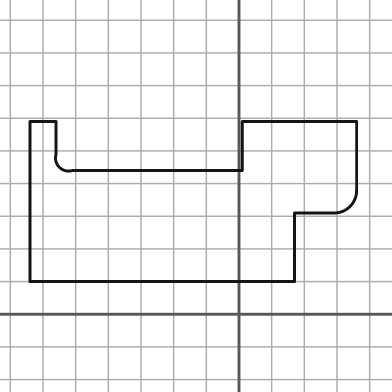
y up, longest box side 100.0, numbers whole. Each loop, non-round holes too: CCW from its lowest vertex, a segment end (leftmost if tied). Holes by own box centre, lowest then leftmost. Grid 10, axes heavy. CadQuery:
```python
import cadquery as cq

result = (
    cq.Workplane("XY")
    .moveTo(-64.0, 10.0)
    .lineTo(17.0, 10.0)
    .lineTo(17.0, 31.0)
    .lineTo(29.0, 31.0)
    .threePointArc((34.0, 33.0), (36.0, 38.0))
    .lineTo(36.0, 59.0)
    .lineTo(1.0, 59.0)
    .lineTo(1.0, 44.0)
    .lineTo(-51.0, 44.0)
    .threePointArc((-55.0, 45.0), (-56.0, 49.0))
    .lineTo(-56.0, 59.0)
    .lineTo(-64.0, 59.0)
    .close()
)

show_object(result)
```